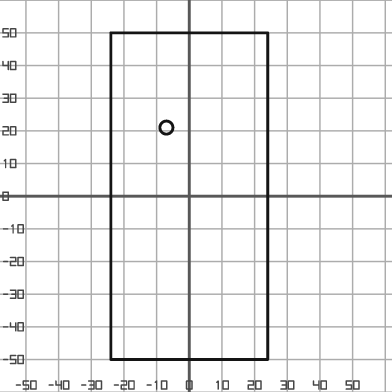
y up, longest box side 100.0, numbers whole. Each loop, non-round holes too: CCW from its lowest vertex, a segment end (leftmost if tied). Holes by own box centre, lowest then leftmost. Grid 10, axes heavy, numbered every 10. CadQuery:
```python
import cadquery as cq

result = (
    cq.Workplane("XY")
    .moveTo(-24.0, -50.0)
    .lineTo(24.0, -50.0)
    .lineTo(24.0, 50.0)
    .lineTo(-24.0, 50.0)
    .close()
    .moveTo(-7.0, 21.0)
    .circle(2.0)
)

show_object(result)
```